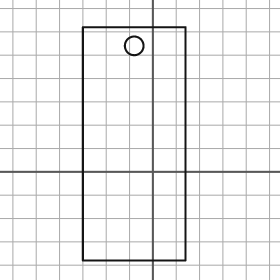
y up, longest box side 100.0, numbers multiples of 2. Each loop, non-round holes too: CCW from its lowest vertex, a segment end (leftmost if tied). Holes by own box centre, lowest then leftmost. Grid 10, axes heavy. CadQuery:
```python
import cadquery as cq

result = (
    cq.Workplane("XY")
    .moveTo(-30.0, -38.0)
    .lineTo(14.0, -38.0)
    .lineTo(14.0, 62.0)
    .lineTo(-30.0, 62.0)
    .close()
    .moveTo(-8.0, 54.0)
    .circle(4.0)
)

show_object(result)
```